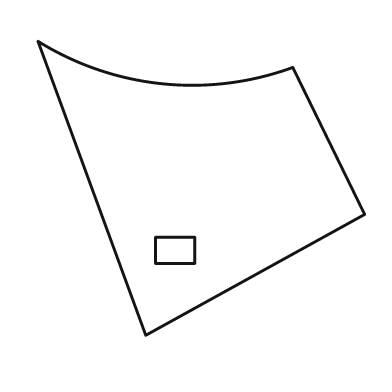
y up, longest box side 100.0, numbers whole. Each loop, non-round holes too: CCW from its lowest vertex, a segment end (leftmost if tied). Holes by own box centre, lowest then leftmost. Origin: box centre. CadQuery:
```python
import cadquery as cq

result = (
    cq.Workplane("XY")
    .moveTo(-17.0, -45.0)
    .lineTo(50.0, -8.0)
    .lineTo(28.0, 37.0)
    .threePointArc((-12.0, 32.0), (-50.0, 45.0))
    .close()
    .moveTo(-14.0, -23.0)
    .lineTo(-2.0, -23.0)
    .lineTo(-2.0, -15.0)
    .lineTo(-14.0, -15.0)
    .close()
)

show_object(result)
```